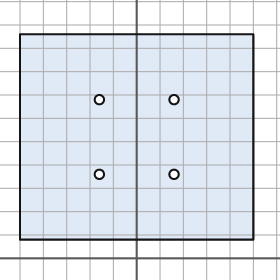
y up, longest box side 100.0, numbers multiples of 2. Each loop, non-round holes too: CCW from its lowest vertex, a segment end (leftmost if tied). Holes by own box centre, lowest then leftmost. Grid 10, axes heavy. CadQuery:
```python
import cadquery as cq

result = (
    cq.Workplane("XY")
    .moveTo(-50.0, 8.0)
    .lineTo(50.0, 8.0)
    .lineTo(50.0, 96.0)
    .lineTo(-50.0, 96.0)
    .close()
    .moveTo(-16.0, 36.0)
    .circle(2.0)
    .moveTo(16.0, 36.0)
    .circle(2.0)
    .moveTo(-16.0, 68.0)
    .circle(2.0)
    .moveTo(16.0, 68.0)
    .circle(2.0)
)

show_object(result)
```